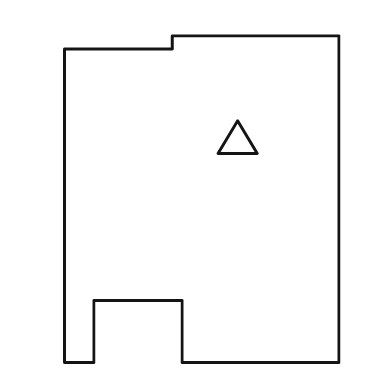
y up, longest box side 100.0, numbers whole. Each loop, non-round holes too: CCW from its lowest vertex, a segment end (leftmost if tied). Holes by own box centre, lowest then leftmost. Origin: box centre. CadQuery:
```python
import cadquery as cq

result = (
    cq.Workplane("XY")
    .moveTo(-42.0, -50.0)
    .lineTo(-33.0, -50.0)
    .lineTo(-33.0, -31.0)
    .lineTo(-6.0, -31.0)
    .lineTo(-6.0, -50.0)
    .lineTo(42.0, -50.0)
    .lineTo(42.0, 50.0)
    .lineTo(-9.0, 50.0)
    .lineTo(-9.0, 46.0)
    .lineTo(-42.0, 46.0)
    .close()
    .moveTo(5.0, 14.0)
    .lineTo(17.0, 14.0)
    .lineTo(11.0, 24.0)
    .close()
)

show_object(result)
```